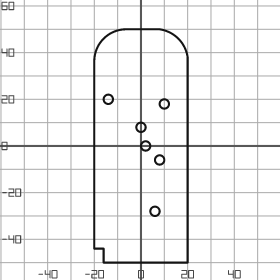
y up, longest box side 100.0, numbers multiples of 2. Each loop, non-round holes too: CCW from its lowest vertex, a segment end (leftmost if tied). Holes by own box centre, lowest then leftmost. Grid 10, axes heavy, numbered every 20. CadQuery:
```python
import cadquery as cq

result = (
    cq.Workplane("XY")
    .moveTo(-16.0, -50.0)
    .lineTo(20.0, -50.0)
    .lineTo(20.0, 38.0)
    .threePointArc((16.0, 46.0), (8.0, 50.0))
    .lineTo(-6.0, 50.0)
    .threePointArc((-16.0, 46.0), (-20.0, 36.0))
    .lineTo(-20.0, -44.0)
    .lineTo(-16.0, -44.0)
    .close()
    .moveTo(6.0, -28.0)
    .circle(2.0)
    .moveTo(8.0, -6.0)
    .circle(2.0)
    .moveTo(2.0, 0.0)
    .circle(2.0)
    .moveTo(0.0, 8.0)
    .circle(2.0)
    .moveTo(10.0, 18.0)
    .circle(2.0)
    .moveTo(-14.0, 20.0)
    .circle(2.0)
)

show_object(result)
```